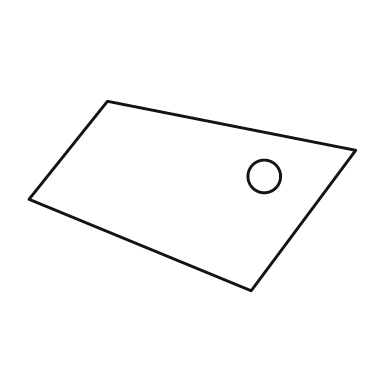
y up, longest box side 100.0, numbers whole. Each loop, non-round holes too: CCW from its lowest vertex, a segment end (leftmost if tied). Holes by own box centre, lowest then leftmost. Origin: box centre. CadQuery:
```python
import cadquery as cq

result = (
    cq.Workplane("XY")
    .moveTo(18.0, -29.0)
    .lineTo(50.0, 14.0)
    .lineTo(-26.0, 29.0)
    .lineTo(-50.0, -1.0)
    .close()
    .moveTo(22.0, 6.0)
    .circle(5.0)
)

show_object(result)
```